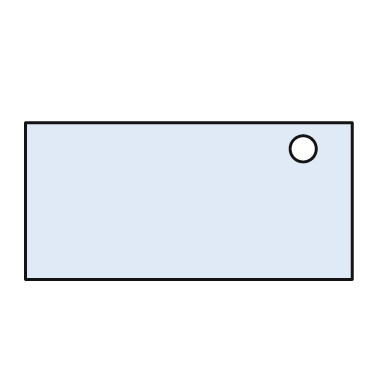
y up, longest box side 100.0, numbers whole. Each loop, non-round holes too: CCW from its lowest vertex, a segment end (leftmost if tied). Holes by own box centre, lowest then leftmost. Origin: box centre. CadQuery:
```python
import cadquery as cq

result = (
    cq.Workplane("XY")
    .moveTo(-50.0, -24.0)
    .lineTo(50.0, -24.0)
    .lineTo(50.0, 24.0)
    .lineTo(-50.0, 24.0)
    .close()
    .moveTo(35.0, 16.0)
    .circle(4.0)
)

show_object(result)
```